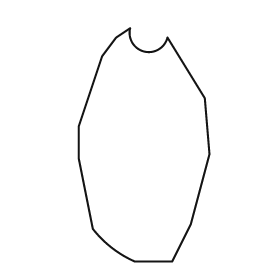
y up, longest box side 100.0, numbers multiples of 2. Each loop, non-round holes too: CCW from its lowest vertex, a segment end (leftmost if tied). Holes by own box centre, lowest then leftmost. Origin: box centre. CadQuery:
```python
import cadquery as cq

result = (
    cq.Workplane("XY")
    .moveTo(-4.0, -50.0)
    .lineTo(12.0, -50.0)
    .lineTo(20.0, -34.0)
    .lineTo(28.0, -4.0)
    .lineTo(26.0, 20.0)
    .lineTo(10.0, 46.0)
    .threePointArc((0.0, 40.0), (-6.0, 50.0))
    .lineTo(-12.0, 46.0)
    .lineTo(-18.0, 38.0)
    .lineTo(-28.0, 8.0)
    .lineTo(-28.0, -6.0)
    .lineTo(-22.0, -36.0)
    .threePointArc((-14.0, -44.0), (-4.0, -50.0))
    .close()
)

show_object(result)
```